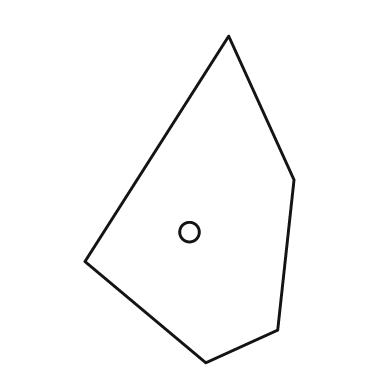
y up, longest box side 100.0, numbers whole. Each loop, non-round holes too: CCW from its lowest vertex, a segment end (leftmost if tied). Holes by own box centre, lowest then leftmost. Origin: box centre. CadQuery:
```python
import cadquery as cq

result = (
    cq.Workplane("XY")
    .moveTo(5.0, -50.0)
    .lineTo(27.0, -40.0)
    .lineTo(32.0, 6.0)
    .lineTo(12.0, 50.0)
    .lineTo(-32.0, -19.0)
    .close()
    .moveTo(0.0, -10.0)
    .circle(3.0)
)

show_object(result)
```